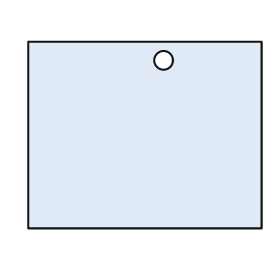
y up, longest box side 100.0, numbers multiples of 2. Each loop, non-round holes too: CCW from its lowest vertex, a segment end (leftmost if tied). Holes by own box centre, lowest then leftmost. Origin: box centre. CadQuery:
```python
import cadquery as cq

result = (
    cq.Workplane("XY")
    .moveTo(-50.0, -40.0)
    .lineTo(50.0, -40.0)
    .lineTo(50.0, 40.0)
    .lineTo(-50.0, 40.0)
    .close()
    .moveTo(8.0, 32.0)
    .circle(4.0)
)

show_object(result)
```